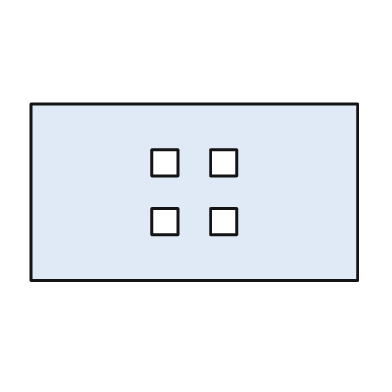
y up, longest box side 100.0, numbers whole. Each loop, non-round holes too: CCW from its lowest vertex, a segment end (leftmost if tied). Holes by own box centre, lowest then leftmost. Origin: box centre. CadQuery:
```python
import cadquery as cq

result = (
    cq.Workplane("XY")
    .moveTo(-50.0, -27.0)
    .lineTo(50.0, -27.0)
    .lineTo(50.0, 27.0)
    .lineTo(-50.0, 27.0)
    .close()
    .moveTo(-13.0, -13.0)
    .lineTo(-5.0, -13.0)
    .lineTo(-5.0, -5.0)
    .lineTo(-13.0, -5.0)
    .close()
    .moveTo(5.0, -13.0)
    .lineTo(13.0, -13.0)
    .lineTo(13.0, -5.0)
    .lineTo(5.0, -5.0)
    .close()
    .moveTo(-13.0, 5.0)
    .lineTo(-5.0, 5.0)
    .lineTo(-5.0, 13.0)
    .lineTo(-13.0, 13.0)
    .close()
    .moveTo(5.0, 5.0)
    .lineTo(13.0, 5.0)
    .lineTo(13.0, 13.0)
    .lineTo(5.0, 13.0)
    .close()
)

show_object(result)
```